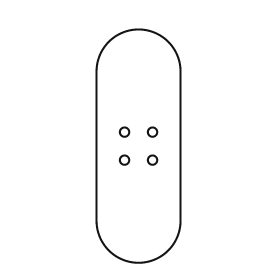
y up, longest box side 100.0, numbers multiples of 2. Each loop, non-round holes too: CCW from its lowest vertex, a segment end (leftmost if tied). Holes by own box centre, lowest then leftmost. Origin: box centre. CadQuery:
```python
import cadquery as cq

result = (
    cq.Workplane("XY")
    .moveTo(-18.0, -32.0)
    .threePointArc((0.0, -50.0), (18.0, -32.0))
    .lineTo(18.0, 32.0)
    .threePointArc((0.0, 50.0), (-18.0, 32.0))
    .close()
    .moveTo(-6.0, -6.0)
    .circle(2.0)
    .moveTo(6.0, -6.0)
    .circle(2.0)
    .moveTo(-6.0, 6.0)
    .circle(2.0)
    .moveTo(6.0, 6.0)
    .circle(2.0)
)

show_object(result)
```